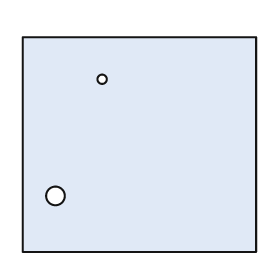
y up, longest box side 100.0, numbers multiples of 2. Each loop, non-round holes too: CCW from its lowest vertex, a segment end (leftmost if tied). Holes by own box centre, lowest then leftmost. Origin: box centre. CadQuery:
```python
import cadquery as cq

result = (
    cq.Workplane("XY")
    .moveTo(-50.0, -46.0)
    .lineTo(50.0, -46.0)
    .lineTo(50.0, 46.0)
    .lineTo(-50.0, 46.0)
    .close()
    .moveTo(-36.0, -22.0)
    .circle(4.0)
    .moveTo(-16.0, 28.0)
    .circle(2.0)
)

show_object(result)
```